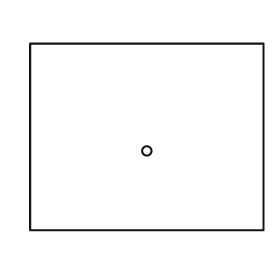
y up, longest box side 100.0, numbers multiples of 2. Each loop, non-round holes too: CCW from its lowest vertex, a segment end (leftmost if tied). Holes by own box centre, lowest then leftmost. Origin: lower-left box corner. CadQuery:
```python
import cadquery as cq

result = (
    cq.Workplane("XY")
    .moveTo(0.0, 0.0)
    .lineTo(100.0, 0.0)
    .lineTo(100.0, 80.0)
    .lineTo(0.0, 80.0)
    .close()
    .moveTo(50.0, 34.0)
    .circle(2.0)
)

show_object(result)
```